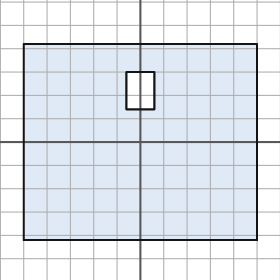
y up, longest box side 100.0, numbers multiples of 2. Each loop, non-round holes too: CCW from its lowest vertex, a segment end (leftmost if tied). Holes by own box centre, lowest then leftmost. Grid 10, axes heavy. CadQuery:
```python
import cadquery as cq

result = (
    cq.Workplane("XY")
    .moveTo(-50.0, -42.0)
    .lineTo(50.0, -42.0)
    .lineTo(50.0, 42.0)
    .lineTo(-50.0, 42.0)
    .close()
    .moveTo(-6.0, 14.0)
    .lineTo(6.0, 14.0)
    .lineTo(6.0, 30.0)
    .lineTo(-6.0, 30.0)
    .close()
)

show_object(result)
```